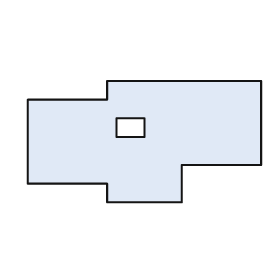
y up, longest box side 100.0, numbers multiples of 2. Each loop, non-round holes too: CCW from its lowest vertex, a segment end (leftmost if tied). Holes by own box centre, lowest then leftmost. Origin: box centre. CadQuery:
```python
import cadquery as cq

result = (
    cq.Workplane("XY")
    .moveTo(-16.0, -26.0)
    .lineTo(16.0, -26.0)
    .lineTo(16.0, -10.0)
    .lineTo(50.0, -10.0)
    .lineTo(50.0, 26.0)
    .lineTo(-16.0, 26.0)
    .lineTo(-16.0, 18.0)
    .lineTo(-50.0, 18.0)
    .lineTo(-50.0, -18.0)
    .lineTo(-16.0, -18.0)
    .close()
    .moveTo(-12.0, 2.0)
    .lineTo(0.0, 2.0)
    .lineTo(0.0, 10.0)
    .lineTo(-12.0, 10.0)
    .close()
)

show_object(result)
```